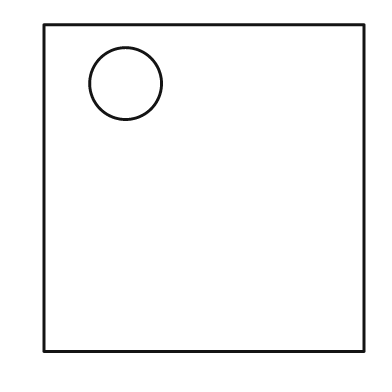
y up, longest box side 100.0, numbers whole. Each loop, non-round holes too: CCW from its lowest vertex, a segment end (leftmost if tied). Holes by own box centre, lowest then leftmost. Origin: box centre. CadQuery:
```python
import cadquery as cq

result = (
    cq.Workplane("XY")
    .moveTo(-49.0, -50.0)
    .lineTo(49.0, -50.0)
    .lineTo(49.0, 50.0)
    .lineTo(-49.0, 50.0)
    .close()
    .moveTo(-24.0, 32.0)
    .circle(11.0)
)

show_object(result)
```